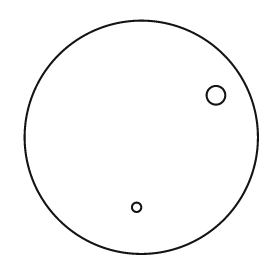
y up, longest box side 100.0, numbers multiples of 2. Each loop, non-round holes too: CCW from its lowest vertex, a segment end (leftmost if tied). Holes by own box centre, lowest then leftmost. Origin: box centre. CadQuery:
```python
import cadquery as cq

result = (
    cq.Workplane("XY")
    .moveTo(0.0, 0.0)
    .circle(50.0)
    .moveTo(-2.0, -30.0)
    .circle(2.0)
    .moveTo(32.0, 18.0)
    .circle(4.0)
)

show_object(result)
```